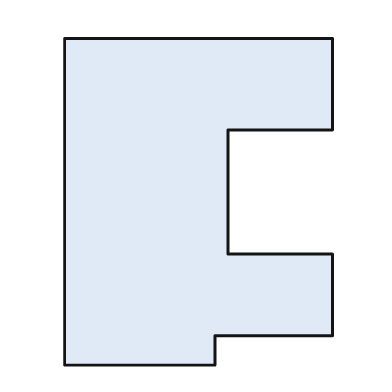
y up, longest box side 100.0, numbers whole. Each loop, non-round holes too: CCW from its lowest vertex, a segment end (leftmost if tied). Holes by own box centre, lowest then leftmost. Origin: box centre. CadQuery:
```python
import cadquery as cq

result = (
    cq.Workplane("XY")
    .moveTo(-41.0, -50.0)
    .lineTo(5.0, -50.0)
    .lineTo(5.0, -41.0)
    .lineTo(41.0, -41.0)
    .lineTo(41.0, -16.0)
    .lineTo(9.0, -16.0)
    .lineTo(9.0, 22.0)
    .lineTo(41.0, 22.0)
    .lineTo(41.0, 50.0)
    .lineTo(-41.0, 50.0)
    .close()
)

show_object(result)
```